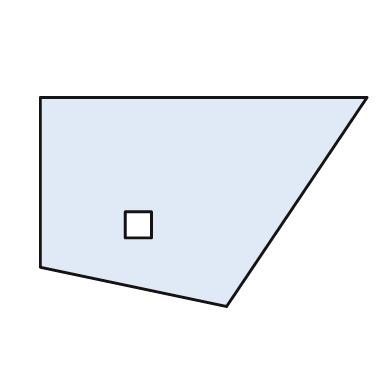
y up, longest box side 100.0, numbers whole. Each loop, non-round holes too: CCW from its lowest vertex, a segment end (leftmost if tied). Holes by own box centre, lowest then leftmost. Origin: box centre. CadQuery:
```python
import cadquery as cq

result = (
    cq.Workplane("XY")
    .moveTo(7.0, -32.0)
    .lineTo(50.0, 32.0)
    .lineTo(-50.0, 32.0)
    .lineTo(-50.0, -20.0)
    .close()
    .moveTo(-24.0, -11.0)
    .lineTo(-16.0, -11.0)
    .lineTo(-16.0, -3.0)
    .lineTo(-24.0, -3.0)
    .close()
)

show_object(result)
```